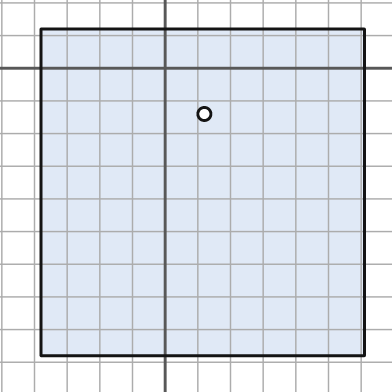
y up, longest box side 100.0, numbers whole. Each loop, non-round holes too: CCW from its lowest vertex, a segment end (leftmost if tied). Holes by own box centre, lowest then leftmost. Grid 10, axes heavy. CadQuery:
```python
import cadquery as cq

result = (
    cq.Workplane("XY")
    .moveTo(-38.0, -88.0)
    .lineTo(61.0, -88.0)
    .lineTo(61.0, 12.0)
    .lineTo(-38.0, 12.0)
    .close()
    .moveTo(12.0, -14.0)
    .circle(2.0)
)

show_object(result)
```